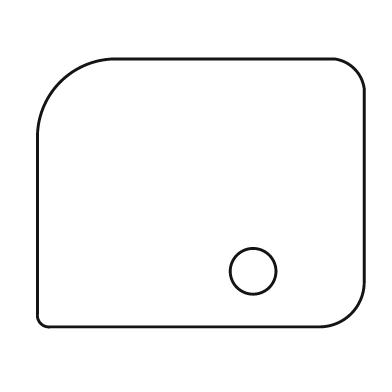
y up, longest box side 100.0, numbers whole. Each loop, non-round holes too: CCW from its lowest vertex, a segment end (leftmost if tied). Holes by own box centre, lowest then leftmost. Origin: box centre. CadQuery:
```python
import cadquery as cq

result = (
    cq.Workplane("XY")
    .moveTo(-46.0, -41.0)
    .lineTo(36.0, -41.0)
    .threePointArc((46.0, -37.0), (50.0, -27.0))
    .lineTo(50.0, 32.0)
    .threePointArc((47.0, 38.0), (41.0, 41.0))
    .lineTo(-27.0, 41.0)
    .threePointArc((-43.0, 34.0), (-50.0, 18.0))
    .lineTo(-50.0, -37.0)
    .threePointArc((-49.0, -40.0), (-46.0, -41.0))
    .close()
    .moveTo(16.0, -24.0)
    .circle(7.0)
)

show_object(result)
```